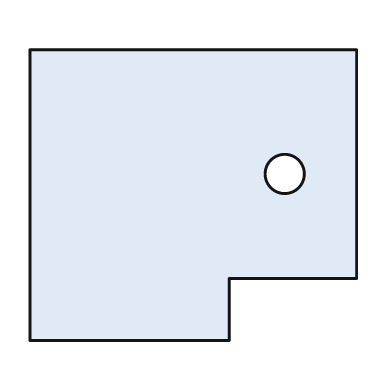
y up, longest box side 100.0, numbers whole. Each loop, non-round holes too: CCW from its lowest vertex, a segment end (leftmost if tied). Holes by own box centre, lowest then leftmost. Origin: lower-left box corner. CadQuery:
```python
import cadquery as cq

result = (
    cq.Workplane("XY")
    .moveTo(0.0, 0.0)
    .lineTo(61.0, 0.0)
    .lineTo(61.0, 19.0)
    .lineTo(100.0, 19.0)
    .lineTo(100.0, 89.0)
    .lineTo(0.0, 89.0)
    .close()
    .moveTo(78.0, 51.0)
    .circle(6.0)
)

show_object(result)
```